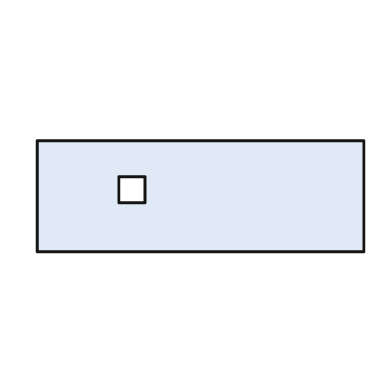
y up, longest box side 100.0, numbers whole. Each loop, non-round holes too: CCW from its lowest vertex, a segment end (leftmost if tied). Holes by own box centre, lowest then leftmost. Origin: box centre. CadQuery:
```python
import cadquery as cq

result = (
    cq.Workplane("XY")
    .moveTo(-50.0, -17.0)
    .lineTo(50.0, -17.0)
    .lineTo(50.0, 17.0)
    .lineTo(-50.0, 17.0)
    .close()
    .moveTo(-25.0, -2.0)
    .lineTo(-17.0, -2.0)
    .lineTo(-17.0, 6.0)
    .lineTo(-25.0, 6.0)
    .close()
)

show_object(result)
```